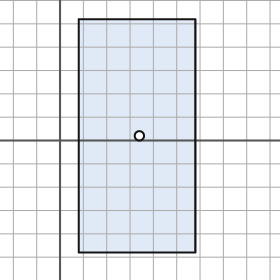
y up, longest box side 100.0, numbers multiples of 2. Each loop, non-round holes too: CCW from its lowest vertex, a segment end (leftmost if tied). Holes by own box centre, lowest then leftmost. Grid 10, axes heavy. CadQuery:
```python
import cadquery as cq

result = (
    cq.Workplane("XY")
    .moveTo(8.0, -48.0)
    .lineTo(58.0, -48.0)
    .lineTo(58.0, 52.0)
    .lineTo(8.0, 52.0)
    .close()
    .moveTo(34.0, 2.0)
    .circle(2.0)
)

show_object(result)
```